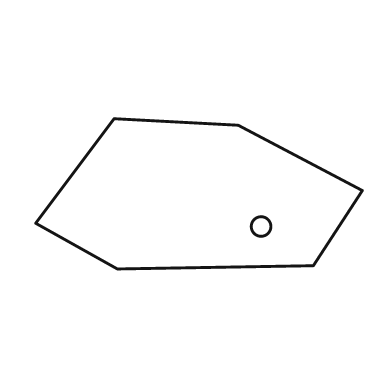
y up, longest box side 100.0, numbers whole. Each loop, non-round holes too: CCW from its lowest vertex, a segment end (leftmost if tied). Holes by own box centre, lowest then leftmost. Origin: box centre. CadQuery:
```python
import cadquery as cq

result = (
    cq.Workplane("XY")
    .moveTo(-25.0, -23.0)
    .lineTo(35.0, -22.0)
    .lineTo(50.0, 1.0)
    .lineTo(12.0, 21.0)
    .lineTo(-26.0, 23.0)
    .lineTo(-50.0, -9.0)
    .close()
    .moveTo(19.0, -10.0)
    .circle(3.0)
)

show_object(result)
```